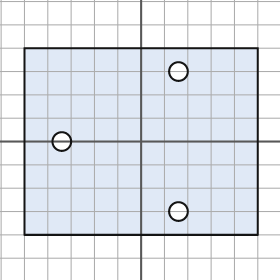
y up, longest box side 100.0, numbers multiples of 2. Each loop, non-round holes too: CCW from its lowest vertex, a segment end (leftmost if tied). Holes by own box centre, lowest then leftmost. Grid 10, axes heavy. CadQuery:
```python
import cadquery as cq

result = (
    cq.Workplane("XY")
    .moveTo(-50.0, -40.0)
    .lineTo(50.0, -40.0)
    .lineTo(50.0, 40.0)
    .lineTo(-50.0, 40.0)
    .close()
    .moveTo(16.0, -30.0)
    .circle(4.0)
    .moveTo(-34.0, 0.0)
    .circle(4.0)
    .moveTo(16.0, 30.0)
    .circle(4.0)
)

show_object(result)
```